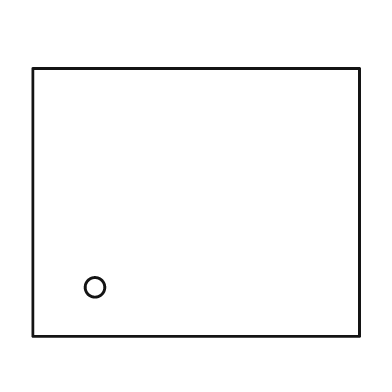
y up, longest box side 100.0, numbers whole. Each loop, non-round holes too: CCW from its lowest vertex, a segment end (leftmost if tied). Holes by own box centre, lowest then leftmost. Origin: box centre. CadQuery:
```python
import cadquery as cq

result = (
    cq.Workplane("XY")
    .moveTo(-50.0, -41.0)
    .lineTo(50.0, -41.0)
    .lineTo(50.0, 41.0)
    .lineTo(-50.0, 41.0)
    .close()
    .moveTo(-31.0, -26.0)
    .circle(3.0)
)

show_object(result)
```